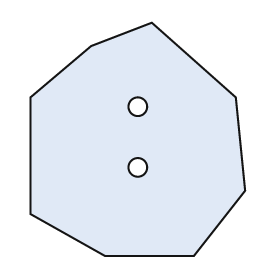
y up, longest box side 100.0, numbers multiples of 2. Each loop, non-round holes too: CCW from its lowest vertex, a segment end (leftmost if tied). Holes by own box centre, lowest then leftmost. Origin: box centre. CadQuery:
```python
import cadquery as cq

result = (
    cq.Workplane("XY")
    .moveTo(-14.0, -50.0)
    .lineTo(24.0, -50.0)
    .lineTo(46.0, -22.0)
    .lineTo(42.0, 18.0)
    .lineTo(6.0, 50.0)
    .lineTo(-20.0, 40.0)
    .lineTo(-46.0, 18.0)
    .lineTo(-46.0, -32.0)
    .close()
    .moveTo(0.0, -12.0)
    .circle(4.0)
    .moveTo(0.0, 14.0)
    .circle(4.0)
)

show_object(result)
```